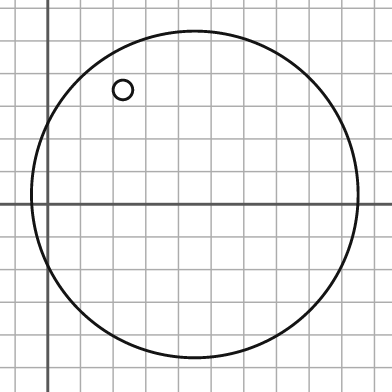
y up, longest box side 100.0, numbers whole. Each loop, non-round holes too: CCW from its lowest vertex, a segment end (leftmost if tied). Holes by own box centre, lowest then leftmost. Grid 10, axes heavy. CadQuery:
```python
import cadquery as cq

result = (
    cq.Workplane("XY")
    .moveTo(45.0, 3.0)
    .circle(50.0)
    .moveTo(23.0, 35.0)
    .circle(3.0)
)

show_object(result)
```